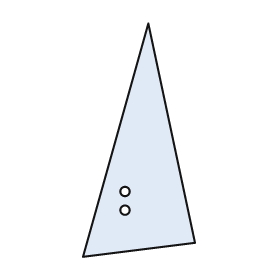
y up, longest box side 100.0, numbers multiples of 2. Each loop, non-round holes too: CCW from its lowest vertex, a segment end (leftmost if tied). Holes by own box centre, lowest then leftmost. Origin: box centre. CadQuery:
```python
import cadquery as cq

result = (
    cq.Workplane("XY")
    .moveTo(-24.0, -50.0)
    .lineTo(24.0, -44.0)
    .lineTo(4.0, 50.0)
    .close()
    .moveTo(-6.0, -30.0)
    .circle(2.0)
    .moveTo(-6.0, -22.0)
    .circle(2.0)
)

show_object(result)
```